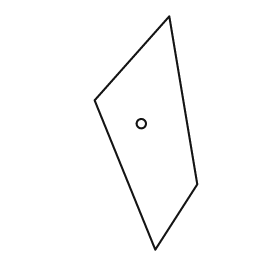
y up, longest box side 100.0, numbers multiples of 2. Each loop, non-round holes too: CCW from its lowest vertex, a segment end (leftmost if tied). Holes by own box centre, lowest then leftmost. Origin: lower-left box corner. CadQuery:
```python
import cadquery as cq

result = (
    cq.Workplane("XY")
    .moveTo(26.0, 0.0)
    .lineTo(44.0, 28.0)
    .lineTo(32.0, 100.0)
    .lineTo(0.0, 64.0)
    .close()
    .moveTo(20.0, 54.0)
    .circle(2.0)
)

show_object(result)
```